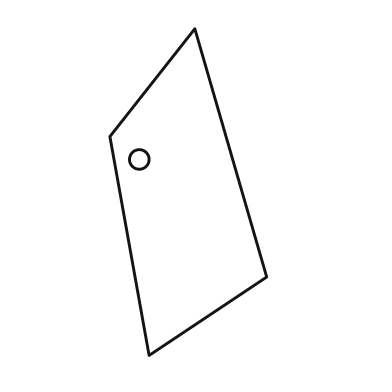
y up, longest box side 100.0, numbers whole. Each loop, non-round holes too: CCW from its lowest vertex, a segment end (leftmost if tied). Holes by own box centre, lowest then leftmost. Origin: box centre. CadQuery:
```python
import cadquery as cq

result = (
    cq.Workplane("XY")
    .moveTo(-12.0, -50.0)
    .lineTo(24.0, -26.0)
    .lineTo(2.0, 50.0)
    .lineTo(-24.0, 17.0)
    .close()
    .moveTo(-15.0, 10.0)
    .circle(3.0)
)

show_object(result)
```